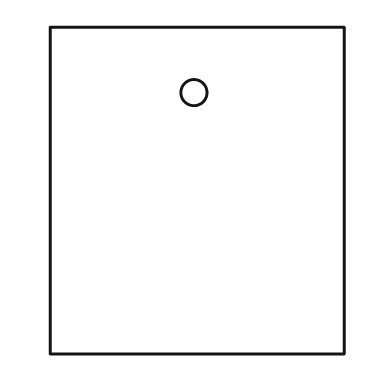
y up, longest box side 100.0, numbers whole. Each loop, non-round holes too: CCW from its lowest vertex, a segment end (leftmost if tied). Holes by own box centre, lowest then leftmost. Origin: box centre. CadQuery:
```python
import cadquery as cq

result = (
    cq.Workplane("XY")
    .moveTo(-45.0, -50.0)
    .lineTo(45.0, -50.0)
    .lineTo(45.0, 50.0)
    .lineTo(-45.0, 50.0)
    .close()
    .moveTo(-1.0, 30.0)
    .circle(4.0)
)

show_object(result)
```